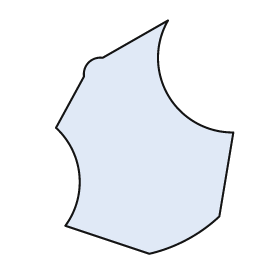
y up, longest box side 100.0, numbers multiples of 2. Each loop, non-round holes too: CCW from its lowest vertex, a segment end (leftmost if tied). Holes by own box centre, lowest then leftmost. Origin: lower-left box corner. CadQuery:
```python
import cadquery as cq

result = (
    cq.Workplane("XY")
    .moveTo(40.0, 0.0)
    .threePointArc((56.0, 6.0), (70.0, 16.0))
    .lineTo(76.0, 52.0)
    .threePointArc((48.0, 68.0), (48.0, 100.0))
    .lineTo(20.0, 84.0)
    .threePointArc((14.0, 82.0), (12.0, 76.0))
    .lineTo(0.0, 54.0)
    .threePointArc((10.0, 34.0), (4.0, 12.0))
    .close()
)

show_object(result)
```